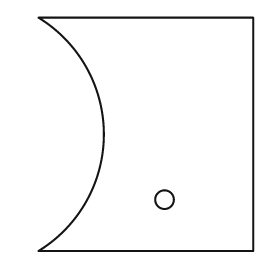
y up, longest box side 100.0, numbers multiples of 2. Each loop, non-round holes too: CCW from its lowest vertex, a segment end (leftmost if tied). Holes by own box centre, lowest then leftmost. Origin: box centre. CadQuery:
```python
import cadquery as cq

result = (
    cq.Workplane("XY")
    .moveTo(-46.0, -50.0)
    .lineTo(46.0, -50.0)
    .lineTo(46.0, 50.0)
    .lineTo(-46.0, 50.0)
    .threePointArc((-18.0, 0.0), (-46.0, -50.0))
    .close()
    .moveTo(8.0, -28.0)
    .circle(4.0)
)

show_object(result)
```